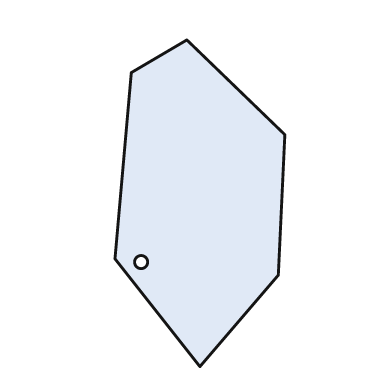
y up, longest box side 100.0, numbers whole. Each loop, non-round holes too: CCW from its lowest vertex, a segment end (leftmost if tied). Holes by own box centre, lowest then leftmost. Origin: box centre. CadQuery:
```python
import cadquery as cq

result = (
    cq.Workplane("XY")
    .moveTo(0.0, -50.0)
    .lineTo(24.0, -22.0)
    .lineTo(26.0, 21.0)
    .lineTo(-4.0, 50.0)
    .lineTo(-21.0, 40.0)
    .lineTo(-26.0, -17.0)
    .close()
    .moveTo(-18.0, -18.0)
    .circle(2.0)
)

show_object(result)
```